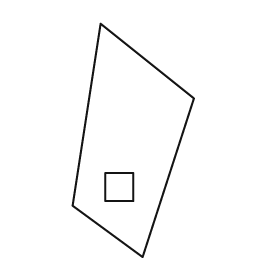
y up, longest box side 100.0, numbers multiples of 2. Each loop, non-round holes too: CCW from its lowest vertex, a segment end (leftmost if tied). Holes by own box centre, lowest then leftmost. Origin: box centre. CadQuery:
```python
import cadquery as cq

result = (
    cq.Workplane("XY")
    .moveTo(4.0, -50.0)
    .lineTo(26.0, 18.0)
    .lineTo(-14.0, 50.0)
    .lineTo(-26.0, -28.0)
    .close()
    .moveTo(-12.0, -26.0)
    .lineTo(0.0, -26.0)
    .lineTo(0.0, -14.0)
    .lineTo(-12.0, -14.0)
    .close()
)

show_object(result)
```